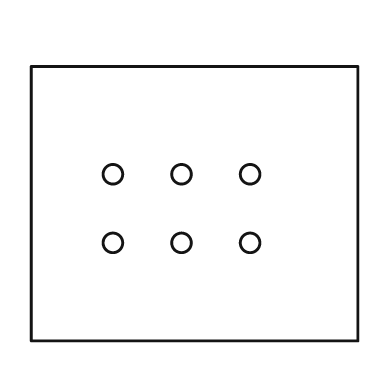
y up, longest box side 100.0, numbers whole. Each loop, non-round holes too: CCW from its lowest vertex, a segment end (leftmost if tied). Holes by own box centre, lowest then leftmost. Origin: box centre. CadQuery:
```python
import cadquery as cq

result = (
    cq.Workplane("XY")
    .moveTo(-50.0, -42.0)
    .lineTo(50.0, -42.0)
    .lineTo(50.0, 42.0)
    .lineTo(-50.0, 42.0)
    .close()
    .moveTo(-25.0, -12.0)
    .circle(3.0)
    .moveTo(-4.0, -12.0)
    .circle(3.0)
    .moveTo(17.0, -12.0)
    .circle(3.0)
    .moveTo(-25.0, 9.0)
    .circle(3.0)
    .moveTo(-4.0, 9.0)
    .circle(3.0)
    .moveTo(17.0, 9.0)
    .circle(3.0)
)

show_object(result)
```